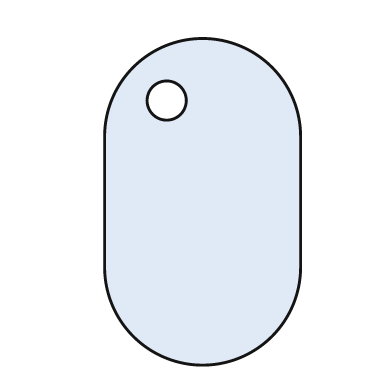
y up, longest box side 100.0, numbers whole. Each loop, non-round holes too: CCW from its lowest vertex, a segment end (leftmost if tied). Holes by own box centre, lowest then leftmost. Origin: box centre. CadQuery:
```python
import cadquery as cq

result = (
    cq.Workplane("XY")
    .moveTo(-30.0, -20.0)
    .threePointArc((0.0, -50.0), (30.0, -20.0))
    .lineTo(30.0, 20.0)
    .threePointArc((0.0, 50.0), (-30.0, 20.0))
    .close()
    .moveTo(-11.0, 31.0)
    .circle(6.0)
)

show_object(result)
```